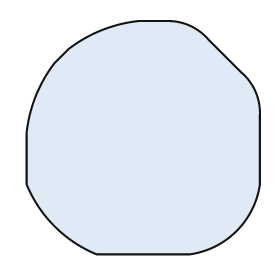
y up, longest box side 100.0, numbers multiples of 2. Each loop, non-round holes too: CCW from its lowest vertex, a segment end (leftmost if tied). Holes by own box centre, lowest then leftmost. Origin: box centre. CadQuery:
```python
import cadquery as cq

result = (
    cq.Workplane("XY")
    .moveTo(-20.0, -50.0)
    .lineTo(20.0, -50.0)
    .threePointArc((40.0, -40.0), (50.0, -20.0))
    .lineTo(50.0, 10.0)
    .threePointArc((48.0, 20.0), (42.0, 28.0))
    .lineTo(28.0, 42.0)
    .threePointArc((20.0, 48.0), (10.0, 50.0))
    .lineTo(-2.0, 50.0)
    .threePointArc((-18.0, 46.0), (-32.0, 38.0))
    .lineTo(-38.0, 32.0)
    .threePointArc((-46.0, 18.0), (-50.0, 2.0))
    .lineTo(-50.0, -20.0)
    .threePointArc((-38.0, -38.0), (-20.0, -50.0))
    .close()
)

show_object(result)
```